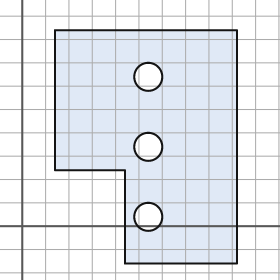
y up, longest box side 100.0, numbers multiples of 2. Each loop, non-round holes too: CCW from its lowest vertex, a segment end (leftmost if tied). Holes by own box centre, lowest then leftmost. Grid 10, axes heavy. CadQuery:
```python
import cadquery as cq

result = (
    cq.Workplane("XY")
    .moveTo(44.0, -16.0)
    .lineTo(92.0, -16.0)
    .lineTo(92.0, 84.0)
    .lineTo(14.0, 84.0)
    .lineTo(14.0, 24.0)
    .lineTo(44.0, 24.0)
    .close()
    .moveTo(54.0, 4.0)
    .circle(6.0)
    .moveTo(54.0, 34.0)
    .circle(6.0)
    .moveTo(54.0, 64.0)
    .circle(6.0)
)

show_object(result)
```